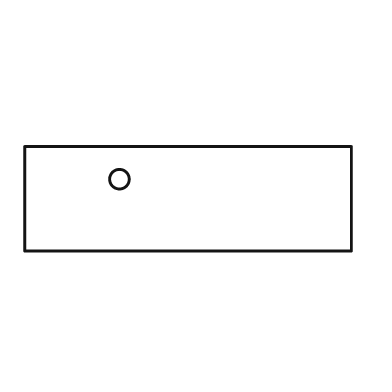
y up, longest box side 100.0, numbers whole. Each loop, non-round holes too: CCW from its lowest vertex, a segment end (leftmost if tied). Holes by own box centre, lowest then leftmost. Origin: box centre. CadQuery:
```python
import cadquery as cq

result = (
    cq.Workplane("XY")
    .moveTo(-50.0, -16.0)
    .lineTo(50.0, -16.0)
    .lineTo(50.0, 16.0)
    .lineTo(-50.0, 16.0)
    .close()
    .moveTo(-21.0, 6.0)
    .circle(3.0)
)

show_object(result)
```